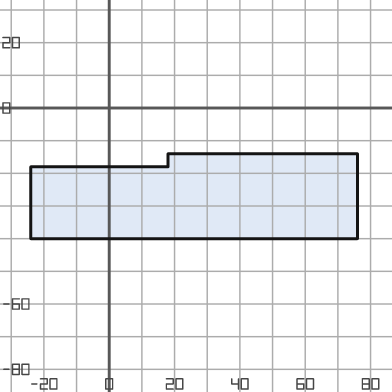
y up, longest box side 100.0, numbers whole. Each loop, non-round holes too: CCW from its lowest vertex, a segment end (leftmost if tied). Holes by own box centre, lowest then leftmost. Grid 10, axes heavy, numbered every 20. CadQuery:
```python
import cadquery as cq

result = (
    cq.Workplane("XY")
    .moveTo(-24.0, -40.0)
    .lineTo(76.0, -40.0)
    .lineTo(76.0, -14.0)
    .lineTo(18.0, -14.0)
    .lineTo(18.0, -18.0)
    .lineTo(-24.0, -18.0)
    .close()
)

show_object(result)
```